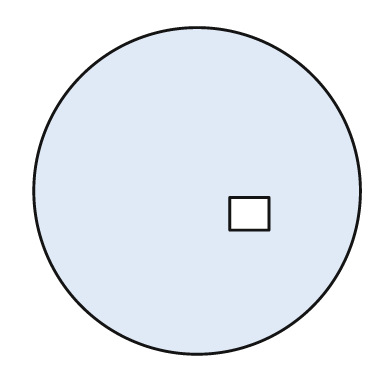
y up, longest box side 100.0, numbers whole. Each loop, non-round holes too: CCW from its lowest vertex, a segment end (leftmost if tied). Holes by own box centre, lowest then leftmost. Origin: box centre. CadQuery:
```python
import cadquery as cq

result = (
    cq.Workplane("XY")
    .moveTo(0.0, 0.0)
    .circle(50.0)
    .moveTo(10.0, -12.0)
    .lineTo(22.0, -12.0)
    .lineTo(22.0, -2.0)
    .lineTo(10.0, -2.0)
    .close()
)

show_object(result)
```